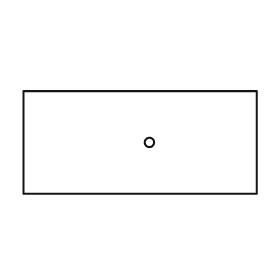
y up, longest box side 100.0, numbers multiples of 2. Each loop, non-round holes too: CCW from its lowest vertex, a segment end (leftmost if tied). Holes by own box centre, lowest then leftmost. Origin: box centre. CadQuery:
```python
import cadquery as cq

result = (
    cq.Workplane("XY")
    .moveTo(-50.0, -22.0)
    .lineTo(50.0, -22.0)
    .lineTo(50.0, 22.0)
    .lineTo(-50.0, 22.0)
    .close()
    .moveTo(4.0, 0.0)
    .circle(2.0)
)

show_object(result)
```